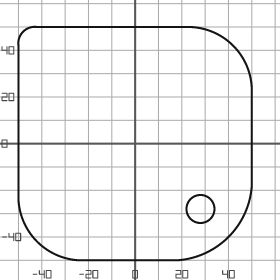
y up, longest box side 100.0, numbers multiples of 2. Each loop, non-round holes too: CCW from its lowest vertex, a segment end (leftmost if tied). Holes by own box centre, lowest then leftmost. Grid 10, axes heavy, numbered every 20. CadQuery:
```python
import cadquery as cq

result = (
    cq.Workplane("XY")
    .moveTo(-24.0, -50.0)
    .lineTo(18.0, -50.0)
    .threePointArc((40.0, -40.0), (50.0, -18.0))
    .lineTo(50.0, 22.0)
    .threePointArc((42.0, 42.0), (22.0, 50.0))
    .lineTo(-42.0, 50.0)
    .threePointArc((-48.0, 48.0), (-50.0, 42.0))
    .lineTo(-50.0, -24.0)
    .threePointArc((-42.0, -42.0), (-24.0, -50.0))
    .close()
    .moveTo(28.0, -28.0)
    .circle(6.0)
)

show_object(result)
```